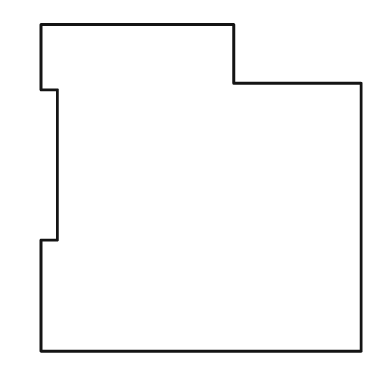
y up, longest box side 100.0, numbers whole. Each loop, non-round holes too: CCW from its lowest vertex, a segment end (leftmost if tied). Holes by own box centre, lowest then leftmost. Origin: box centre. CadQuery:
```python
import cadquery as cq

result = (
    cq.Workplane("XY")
    .moveTo(-49.0, -50.0)
    .lineTo(49.0, -50.0)
    .lineTo(49.0, 32.0)
    .lineTo(10.0, 32.0)
    .lineTo(10.0, 50.0)
    .lineTo(-49.0, 50.0)
    .lineTo(-49.0, 30.0)
    .lineTo(-44.0, 30.0)
    .lineTo(-44.0, -16.0)
    .lineTo(-49.0, -16.0)
    .close()
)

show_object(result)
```